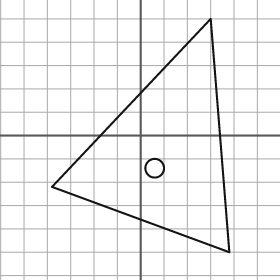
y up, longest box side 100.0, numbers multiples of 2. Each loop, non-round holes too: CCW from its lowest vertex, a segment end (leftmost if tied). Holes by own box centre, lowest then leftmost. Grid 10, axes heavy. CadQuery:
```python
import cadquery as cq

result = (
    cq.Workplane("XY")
    .moveTo(38.0, -50.0)
    .lineTo(30.0, 50.0)
    .lineTo(-38.0, -22.0)
    .close()
    .moveTo(6.0, -14.0)
    .circle(4.0)
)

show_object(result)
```